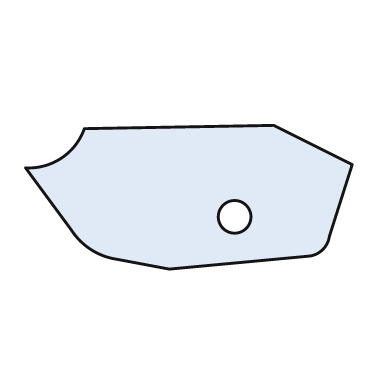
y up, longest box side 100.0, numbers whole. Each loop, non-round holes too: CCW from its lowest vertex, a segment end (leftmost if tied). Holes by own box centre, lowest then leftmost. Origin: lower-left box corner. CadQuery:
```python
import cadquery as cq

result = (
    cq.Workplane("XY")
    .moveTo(44.0, 0.0)
    .lineTo(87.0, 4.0)
    .threePointArc((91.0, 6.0), (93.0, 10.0))
    .lineTo(100.0, 32.0)
    .lineTo(76.0, 44.0)
    .lineTo(18.0, 43.0)
    .threePointArc((11.0, 34.0), (0.0, 31.0))
    .lineTo(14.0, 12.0)
    .threePointArc((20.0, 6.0), (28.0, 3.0))
    .close()
    .moveTo(64.0, 16.0)
    .circle(5.0)
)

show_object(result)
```